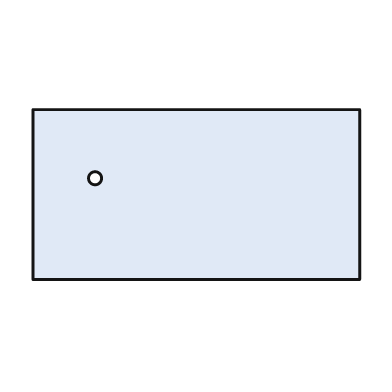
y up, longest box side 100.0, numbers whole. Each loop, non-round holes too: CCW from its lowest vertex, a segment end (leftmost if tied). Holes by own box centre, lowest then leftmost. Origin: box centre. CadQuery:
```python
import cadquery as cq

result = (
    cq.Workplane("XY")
    .moveTo(-50.0, -26.0)
    .lineTo(50.0, -26.0)
    .lineTo(50.0, 26.0)
    .lineTo(-50.0, 26.0)
    .close()
    .moveTo(-31.0, 5.0)
    .circle(2.0)
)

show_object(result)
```